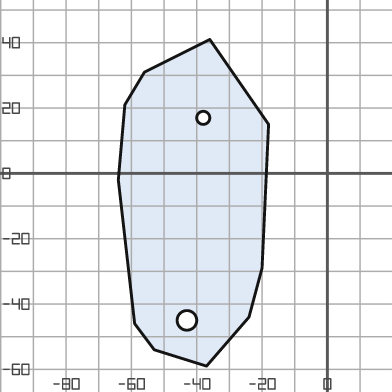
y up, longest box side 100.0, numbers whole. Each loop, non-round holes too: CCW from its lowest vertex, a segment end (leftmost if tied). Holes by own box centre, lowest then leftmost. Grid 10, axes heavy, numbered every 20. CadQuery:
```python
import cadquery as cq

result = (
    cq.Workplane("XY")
    .moveTo(-37.0, -59.0)
    .lineTo(-24.0, -44.0)
    .lineTo(-20.0, -29.0)
    .lineTo(-18.0, 15.0)
    .lineTo(-36.0, 41.0)
    .lineTo(-56.0, 31.0)
    .lineTo(-62.0, 21.0)
    .lineTo(-64.0, -2.0)
    .lineTo(-59.0, -46.0)
    .lineTo(-53.0, -54.0)
    .close()
    .moveTo(-43.0, -45.0)
    .circle(3.0)
    .moveTo(-38.0, 17.0)
    .circle(2.0)
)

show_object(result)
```